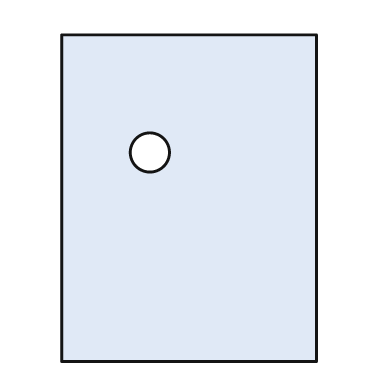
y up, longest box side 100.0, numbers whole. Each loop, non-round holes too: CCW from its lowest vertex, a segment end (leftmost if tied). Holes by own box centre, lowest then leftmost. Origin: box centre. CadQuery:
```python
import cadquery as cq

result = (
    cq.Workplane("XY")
    .moveTo(-39.0, -50.0)
    .lineTo(39.0, -50.0)
    .lineTo(39.0, 50.0)
    .lineTo(-39.0, 50.0)
    .close()
    .moveTo(-12.0, 14.0)
    .circle(6.0)
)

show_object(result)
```